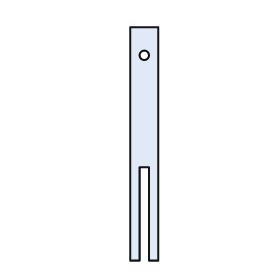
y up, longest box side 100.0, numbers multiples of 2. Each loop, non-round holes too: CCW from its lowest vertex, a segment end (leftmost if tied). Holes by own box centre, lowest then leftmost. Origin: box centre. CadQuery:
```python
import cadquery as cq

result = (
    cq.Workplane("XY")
    .moveTo(-6.0, -50.0)
    .lineTo(-2.0, -50.0)
    .lineTo(-2.0, -10.0)
    .lineTo(2.0, -10.0)
    .lineTo(2.0, -50.0)
    .lineTo(6.0, -50.0)
    .lineTo(6.0, 50.0)
    .lineTo(-6.0, 50.0)
    .close()
    .moveTo(0.0, 38.0)
    .circle(2.0)
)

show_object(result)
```